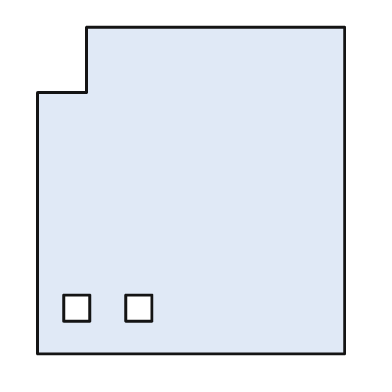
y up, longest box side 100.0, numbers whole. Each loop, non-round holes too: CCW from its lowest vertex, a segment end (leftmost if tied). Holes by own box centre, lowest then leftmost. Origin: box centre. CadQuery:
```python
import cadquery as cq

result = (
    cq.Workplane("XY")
    .moveTo(-47.0, -50.0)
    .lineTo(47.0, -50.0)
    .lineTo(47.0, 50.0)
    .lineTo(-32.0, 50.0)
    .lineTo(-32.0, 30.0)
    .lineTo(-47.0, 30.0)
    .close()
    .moveTo(-39.0, -40.0)
    .lineTo(-31.0, -40.0)
    .lineTo(-31.0, -32.0)
    .lineTo(-39.0, -32.0)
    .close()
    .moveTo(-20.0, -40.0)
    .lineTo(-12.0, -40.0)
    .lineTo(-12.0, -32.0)
    .lineTo(-20.0, -32.0)
    .close()
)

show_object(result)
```